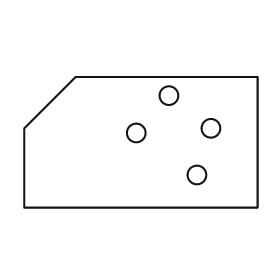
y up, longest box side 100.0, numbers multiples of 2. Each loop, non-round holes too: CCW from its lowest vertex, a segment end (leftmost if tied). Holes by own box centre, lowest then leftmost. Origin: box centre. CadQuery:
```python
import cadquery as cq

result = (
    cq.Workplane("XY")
    .moveTo(-50.0, -28.0)
    .lineTo(50.0, -28.0)
    .lineTo(50.0, 28.0)
    .lineTo(-28.0, 28.0)
    .lineTo(-50.0, 6.0)
    .close()
    .moveTo(24.0, -14.0)
    .circle(4.0)
    .moveTo(-2.0, 4.0)
    .circle(4.0)
    .moveTo(30.0, 6.0)
    .circle(4.0)
    .moveTo(12.0, 20.0)
    .circle(4.0)
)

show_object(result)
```